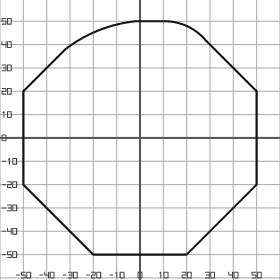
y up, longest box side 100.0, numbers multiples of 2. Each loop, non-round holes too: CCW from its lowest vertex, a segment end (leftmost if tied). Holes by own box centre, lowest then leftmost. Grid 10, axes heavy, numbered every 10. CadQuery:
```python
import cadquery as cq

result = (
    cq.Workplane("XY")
    .moveTo(-20.0, -50.0)
    .lineTo(20.0, -50.0)
    .lineTo(50.0, -20.0)
    .lineTo(50.0, 20.0)
    .lineTo(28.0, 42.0)
    .threePointArc((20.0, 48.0), (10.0, 50.0))
    .lineTo(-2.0, 50.0)
    .threePointArc((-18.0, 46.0), (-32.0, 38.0))
    .lineTo(-50.0, 20.0)
    .lineTo(-50.0, -20.0)
    .close()
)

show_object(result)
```